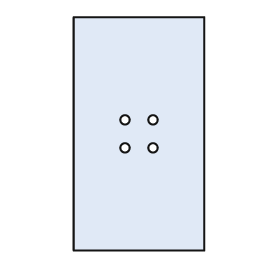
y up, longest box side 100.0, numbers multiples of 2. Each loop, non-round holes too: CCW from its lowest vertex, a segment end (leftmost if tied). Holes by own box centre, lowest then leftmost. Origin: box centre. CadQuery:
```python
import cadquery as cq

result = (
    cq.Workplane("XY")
    .moveTo(-28.0, -50.0)
    .lineTo(28.0, -50.0)
    .lineTo(28.0, 50.0)
    .lineTo(-28.0, 50.0)
    .close()
    .moveTo(-6.0, -6.0)
    .circle(2.0)
    .moveTo(6.0, -6.0)
    .circle(2.0)
    .moveTo(-6.0, 6.0)
    .circle(2.0)
    .moveTo(6.0, 6.0)
    .circle(2.0)
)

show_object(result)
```